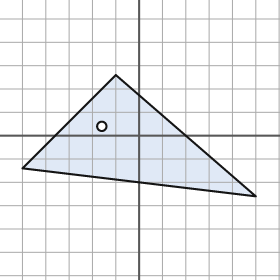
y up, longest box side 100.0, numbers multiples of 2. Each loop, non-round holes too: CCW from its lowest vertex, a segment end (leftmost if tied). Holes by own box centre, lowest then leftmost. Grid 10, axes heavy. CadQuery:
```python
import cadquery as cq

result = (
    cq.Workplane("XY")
    .moveTo(50.0, -26.0)
    .lineTo(-10.0, 26.0)
    .lineTo(-50.0, -14.0)
    .close()
    .moveTo(-16.0, 4.0)
    .circle(2.0)
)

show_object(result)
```